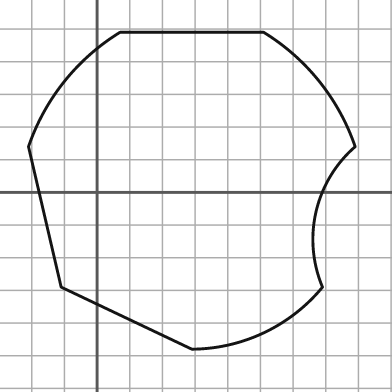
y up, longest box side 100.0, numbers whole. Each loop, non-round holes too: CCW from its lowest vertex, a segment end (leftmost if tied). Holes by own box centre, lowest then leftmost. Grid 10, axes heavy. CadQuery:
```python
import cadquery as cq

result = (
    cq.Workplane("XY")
    .moveTo(29.0, -48.0)
    .threePointArc((51.0, -43.0), (69.0, -29.0))
    .threePointArc((67.0, -6.0), (79.0, 14.0))
    .threePointArc((68.0, 34.0), (51.0, 49.0))
    .lineTo(7.0, 49.0)
    .threePointArc((-10.0, 34.0), (-21.0, 14.0))
    .lineTo(-11.0, -29.0)
    .close()
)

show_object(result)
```